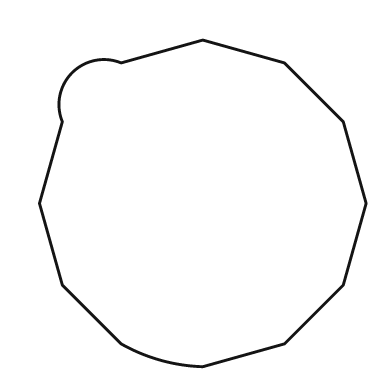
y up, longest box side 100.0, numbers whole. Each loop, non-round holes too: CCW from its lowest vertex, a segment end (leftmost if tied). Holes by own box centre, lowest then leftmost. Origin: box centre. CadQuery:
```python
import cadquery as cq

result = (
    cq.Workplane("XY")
    .moveTo(0.0, -50.0)
    .lineTo(25.0, -43.0)
    .lineTo(43.0, -25.0)
    .lineTo(50.0, 0.0)
    .lineTo(43.0, 25.0)
    .lineTo(25.0, 43.0)
    .lineTo(0.0, 50.0)
    .lineTo(-25.0, 43.0)
    .threePointArc((-40.0, 40.0), (-43.0, 25.0))
    .lineTo(-50.0, 0.0)
    .lineTo(-43.0, -25.0)
    .lineTo(-25.0, -43.0)
    .threePointArc((-13.0, -48.0), (0.0, -50.0))
    .close()
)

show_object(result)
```